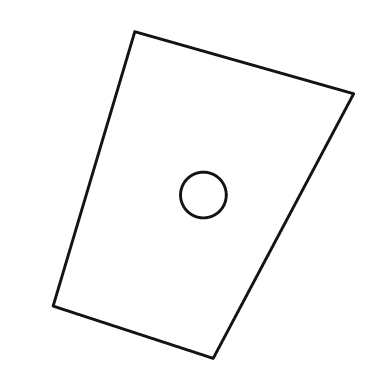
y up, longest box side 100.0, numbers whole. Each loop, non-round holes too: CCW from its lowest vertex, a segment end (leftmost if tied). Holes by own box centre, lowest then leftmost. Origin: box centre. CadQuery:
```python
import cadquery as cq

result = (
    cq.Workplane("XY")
    .moveTo(3.0, -50.0)
    .lineTo(46.0, 31.0)
    .lineTo(-21.0, 50.0)
    .lineTo(-46.0, -34.0)
    .close()
    .moveTo(0.0, 0.0)
    .circle(7.0)
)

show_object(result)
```